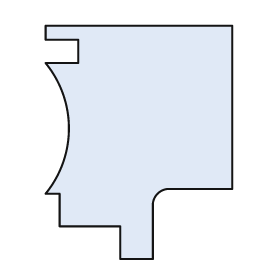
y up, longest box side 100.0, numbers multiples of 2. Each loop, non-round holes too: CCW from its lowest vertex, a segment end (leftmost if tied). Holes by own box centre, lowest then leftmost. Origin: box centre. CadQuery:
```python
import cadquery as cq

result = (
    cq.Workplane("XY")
    .moveTo(-8.0, -50.0)
    .lineTo(6.0, -50.0)
    .lineTo(6.0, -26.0)
    .threePointArc((8.0, -22.0), (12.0, -20.0))
    .lineTo(40.0, -20.0)
    .lineTo(40.0, 50.0)
    .lineTo(-40.0, 50.0)
    .lineTo(-40.0, 44.0)
    .lineTo(-26.0, 44.0)
    .lineTo(-26.0, 34.0)
    .lineTo(-40.0, 34.0)
    .threePointArc((-30.0, 6.0), (-40.0, -22.0))
    .lineTo(-34.0, -22.0)
    .lineTo(-34.0, -36.0)
    .lineTo(-8.0, -36.0)
    .close()
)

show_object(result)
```